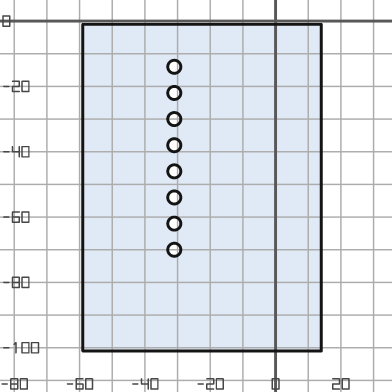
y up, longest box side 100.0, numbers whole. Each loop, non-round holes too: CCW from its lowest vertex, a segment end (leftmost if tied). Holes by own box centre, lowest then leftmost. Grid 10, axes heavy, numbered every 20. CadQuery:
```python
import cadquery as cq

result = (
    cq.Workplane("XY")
    .moveTo(-59.0, -101.0)
    .lineTo(14.0, -101.0)
    .lineTo(14.0, -1.0)
    .lineTo(-59.0, -1.0)
    .close()
    .moveTo(-31.0, -70.0)
    .circle(2.0)
    .moveTo(-31.0, -62.0)
    .circle(2.0)
    .moveTo(-31.0, -54.0)
    .circle(2.0)
    .moveTo(-31.0, -46.0)
    .circle(2.0)
    .moveTo(-31.0, -38.0)
    .circle(2.0)
    .moveTo(-31.0, -30.0)
    .circle(2.0)
    .moveTo(-31.0, -22.0)
    .circle(2.0)
    .moveTo(-31.0, -14.0)
    .circle(2.0)
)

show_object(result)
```